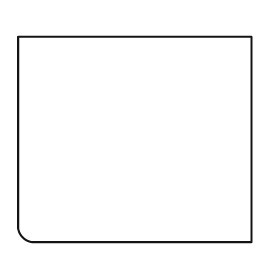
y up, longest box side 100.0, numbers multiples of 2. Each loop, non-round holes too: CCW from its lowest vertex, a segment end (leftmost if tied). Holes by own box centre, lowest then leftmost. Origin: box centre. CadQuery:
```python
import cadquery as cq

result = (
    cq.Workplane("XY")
    .moveTo(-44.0, -44.0)
    .lineTo(50.0, -44.0)
    .lineTo(50.0, 44.0)
    .lineTo(-50.0, 44.0)
    .lineTo(-50.0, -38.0)
    .threePointArc((-48.0, -42.0), (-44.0, -44.0))
    .close()
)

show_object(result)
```